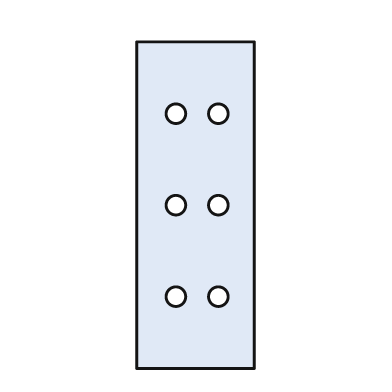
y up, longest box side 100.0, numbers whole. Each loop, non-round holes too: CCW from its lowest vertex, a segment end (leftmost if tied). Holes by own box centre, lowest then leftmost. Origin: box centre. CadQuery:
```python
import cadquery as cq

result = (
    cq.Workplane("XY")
    .moveTo(-18.0, -50.0)
    .lineTo(18.0, -50.0)
    .lineTo(18.0, 50.0)
    .lineTo(-18.0, 50.0)
    .close()
    .moveTo(-6.0, -28.0)
    .circle(3.0)
    .moveTo(7.0, -28.0)
    .circle(3.0)
    .moveTo(-6.0, 0.0)
    .circle(3.0)
    .moveTo(7.0, 0.0)
    .circle(3.0)
    .moveTo(-6.0, 28.0)
    .circle(3.0)
    .moveTo(7.0, 28.0)
    .circle(3.0)
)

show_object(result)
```